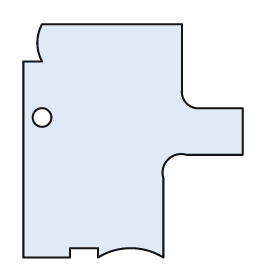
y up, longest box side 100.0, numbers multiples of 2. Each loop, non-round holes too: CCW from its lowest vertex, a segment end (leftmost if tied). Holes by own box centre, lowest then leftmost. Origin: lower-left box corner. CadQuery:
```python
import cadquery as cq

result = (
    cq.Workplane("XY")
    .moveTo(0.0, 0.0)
    .lineTo(20.0, 0.0)
    .lineTo(20.0, 4.0)
    .lineTo(32.0, 4.0)
    .lineTo(32.0, 0.0)
    .threePointArc((46.0, 4.0), (60.0, 0.0))
    .lineTo(60.0, 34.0)
    .threePointArc((62.0, 42.0), (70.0, 44.0))
    .lineTo(94.0, 44.0)
    .lineTo(94.0, 64.0)
    .lineTo(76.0, 64.0)
    .threePointArc((70.0, 66.0), (68.0, 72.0))
    .lineTo(68.0, 100.0)
    .lineTo(8.0, 100.0)
    .threePointArc((6.0, 92.0), (8.0, 84.0))
    .lineTo(0.0, 84.0)
    .close()
    .moveTo(8.0, 60.0)
    .circle(4.0)
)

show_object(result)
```